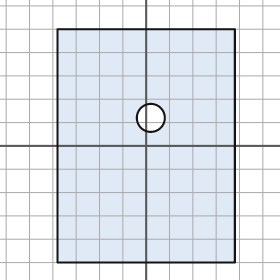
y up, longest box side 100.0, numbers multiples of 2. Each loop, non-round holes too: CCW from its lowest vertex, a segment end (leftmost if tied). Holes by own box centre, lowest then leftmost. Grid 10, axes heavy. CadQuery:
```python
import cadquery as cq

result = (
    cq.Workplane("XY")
    .moveTo(-38.0, -50.0)
    .lineTo(38.0, -50.0)
    .lineTo(38.0, 50.0)
    .lineTo(-38.0, 50.0)
    .close()
    .moveTo(2.0, 12.0)
    .circle(6.0)
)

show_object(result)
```